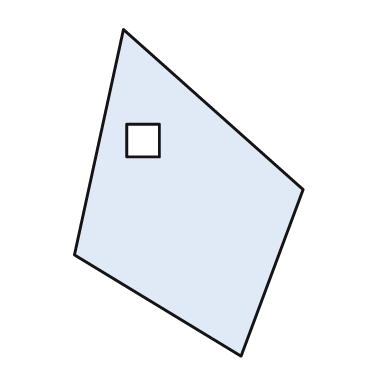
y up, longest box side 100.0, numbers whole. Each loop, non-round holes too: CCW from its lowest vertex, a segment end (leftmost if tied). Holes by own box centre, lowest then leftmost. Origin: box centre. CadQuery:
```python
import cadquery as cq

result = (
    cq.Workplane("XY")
    .moveTo(16.0, -50.0)
    .lineTo(35.0, 1.0)
    .lineTo(-20.0, 50.0)
    .lineTo(-35.0, -19.0)
    .close()
    .moveTo(-19.0, 11.0)
    .lineTo(-9.0, 11.0)
    .lineTo(-9.0, 21.0)
    .lineTo(-19.0, 21.0)
    .close()
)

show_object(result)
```